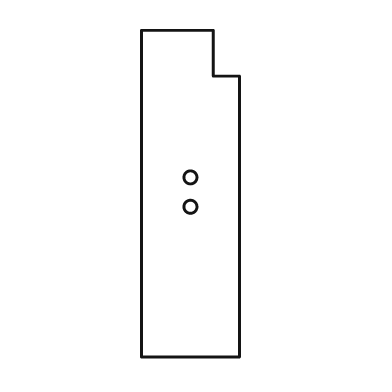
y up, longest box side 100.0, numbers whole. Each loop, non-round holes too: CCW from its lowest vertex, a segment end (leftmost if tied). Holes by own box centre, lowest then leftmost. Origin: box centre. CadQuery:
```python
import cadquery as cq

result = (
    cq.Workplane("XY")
    .moveTo(-15.0, -50.0)
    .lineTo(15.0, -50.0)
    .lineTo(15.0, 36.0)
    .lineTo(7.0, 36.0)
    .lineTo(7.0, 50.0)
    .lineTo(-15.0, 50.0)
    .close()
    .moveTo(0.0, -4.0)
    .circle(2.0)
    .moveTo(0.0, 5.0)
    .circle(2.0)
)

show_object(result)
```